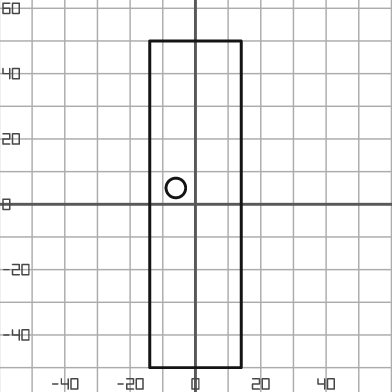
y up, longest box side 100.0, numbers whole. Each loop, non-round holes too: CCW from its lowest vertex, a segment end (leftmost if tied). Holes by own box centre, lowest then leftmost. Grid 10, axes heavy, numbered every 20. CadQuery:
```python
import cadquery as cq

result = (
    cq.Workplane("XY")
    .moveTo(-14.0, -50.0)
    .lineTo(14.0, -50.0)
    .lineTo(14.0, 50.0)
    .lineTo(-14.0, 50.0)
    .close()
    .moveTo(-6.0, 5.0)
    .circle(3.0)
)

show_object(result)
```